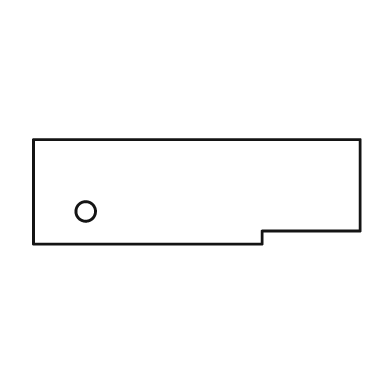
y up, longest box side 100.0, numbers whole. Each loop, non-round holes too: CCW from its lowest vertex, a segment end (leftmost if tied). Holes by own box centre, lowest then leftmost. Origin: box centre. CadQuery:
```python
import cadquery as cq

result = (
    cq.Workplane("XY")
    .moveTo(-50.0, -16.0)
    .lineTo(20.0, -16.0)
    .lineTo(20.0, -12.0)
    .lineTo(50.0, -12.0)
    .lineTo(50.0, 16.0)
    .lineTo(-50.0, 16.0)
    .close()
    .moveTo(-34.0, -6.0)
    .circle(3.0)
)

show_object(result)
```